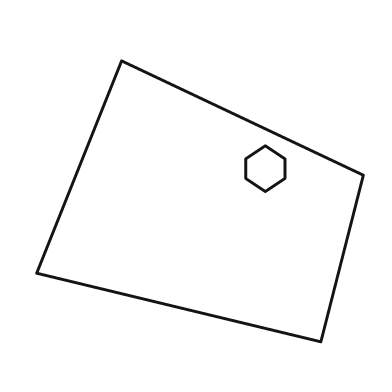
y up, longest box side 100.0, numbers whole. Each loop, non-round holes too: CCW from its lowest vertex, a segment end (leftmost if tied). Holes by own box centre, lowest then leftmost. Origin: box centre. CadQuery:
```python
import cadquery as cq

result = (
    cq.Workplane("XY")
    .moveTo(37.0, -43.0)
    .lineTo(50.0, 8.0)
    .lineTo(-24.0, 43.0)
    .lineTo(-50.0, -22.0)
    .close()
    .moveTo(20.0, 3.0)
    .lineTo(26.0, 7.0)
    .lineTo(26.0, 13.0)
    .lineTo(20.0, 17.0)
    .lineTo(14.0, 13.0)
    .lineTo(14.0, 7.0)
    .close()
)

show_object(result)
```